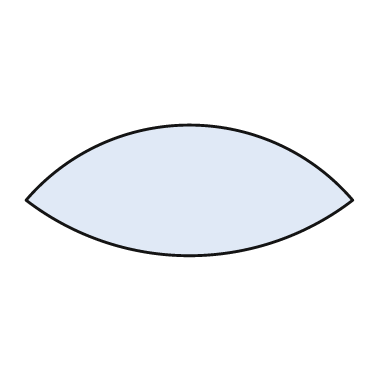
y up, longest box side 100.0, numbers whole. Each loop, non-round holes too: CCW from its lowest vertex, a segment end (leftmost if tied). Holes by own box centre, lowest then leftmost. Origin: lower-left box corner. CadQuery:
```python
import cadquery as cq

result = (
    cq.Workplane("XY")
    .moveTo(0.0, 17.0)
    .threePointArc((50.0, 0.0), (100.0, 17.0))
    .threePointArc((50.0, 40.0), (0.0, 17.0))
    .close()
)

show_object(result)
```